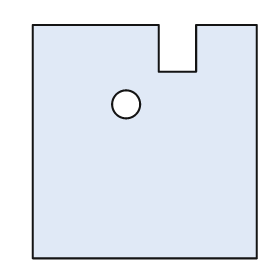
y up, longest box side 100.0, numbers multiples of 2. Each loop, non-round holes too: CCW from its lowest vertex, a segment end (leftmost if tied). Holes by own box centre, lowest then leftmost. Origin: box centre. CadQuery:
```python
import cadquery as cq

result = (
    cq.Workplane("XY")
    .moveTo(-48.0, -50.0)
    .lineTo(48.0, -50.0)
    .lineTo(48.0, 50.0)
    .lineTo(22.0, 50.0)
    .lineTo(22.0, 30.0)
    .lineTo(6.0, 30.0)
    .lineTo(6.0, 50.0)
    .lineTo(-48.0, 50.0)
    .close()
    .moveTo(-8.0, 16.0)
    .circle(6.0)
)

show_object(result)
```